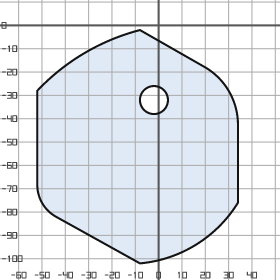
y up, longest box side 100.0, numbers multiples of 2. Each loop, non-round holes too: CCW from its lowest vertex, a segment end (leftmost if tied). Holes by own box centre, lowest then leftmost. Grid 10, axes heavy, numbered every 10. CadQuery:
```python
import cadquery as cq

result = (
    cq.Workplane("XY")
    .moveTo(-8.0, -102.0)
    .threePointArc((16.0, -94.0), (34.0, -76.0))
    .lineTo(34.0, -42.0)
    .threePointArc((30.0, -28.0), (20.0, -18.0))
    .lineTo(-8.0, -2.0)
    .threePointArc((-32.0, -12.0), (-52.0, -28.0))
    .lineTo(-52.0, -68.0)
    .threePointArc((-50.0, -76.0), (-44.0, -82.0))
    .close()
    .moveTo(-2.0, -32.0)
    .circle(6.0)
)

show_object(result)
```